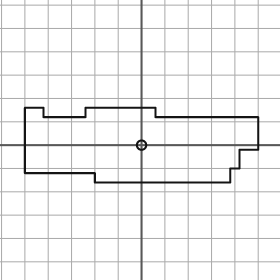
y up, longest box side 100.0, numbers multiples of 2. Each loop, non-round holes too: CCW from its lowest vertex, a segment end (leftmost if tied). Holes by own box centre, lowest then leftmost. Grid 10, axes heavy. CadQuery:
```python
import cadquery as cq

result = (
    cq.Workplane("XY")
    .moveTo(-20.0, -16.0)
    .lineTo(38.0, -16.0)
    .lineTo(38.0, -10.0)
    .lineTo(42.0, -10.0)
    .lineTo(42.0, -2.0)
    .lineTo(50.0, -2.0)
    .lineTo(50.0, 12.0)
    .lineTo(6.0, 12.0)
    .lineTo(6.0, 16.0)
    .lineTo(-24.0, 16.0)
    .lineTo(-24.0, 12.0)
    .lineTo(-42.0, 12.0)
    .lineTo(-42.0, 16.0)
    .lineTo(-50.0, 16.0)
    .lineTo(-50.0, -12.0)
    .lineTo(-20.0, -12.0)
    .close()
    .moveTo(0.0, 0.0)
    .circle(2.0)
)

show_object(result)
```